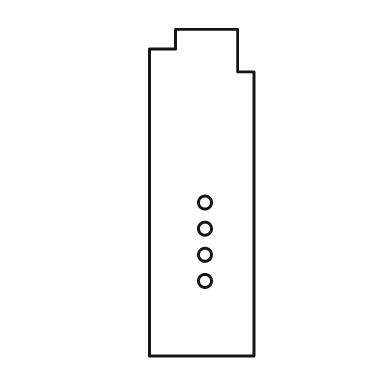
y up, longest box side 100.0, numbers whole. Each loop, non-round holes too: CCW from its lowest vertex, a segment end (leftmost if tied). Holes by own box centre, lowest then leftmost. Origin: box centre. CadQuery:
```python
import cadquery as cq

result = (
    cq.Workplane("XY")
    .moveTo(-16.0, -50.0)
    .lineTo(16.0, -50.0)
    .lineTo(16.0, 37.0)
    .lineTo(11.0, 37.0)
    .lineTo(11.0, 50.0)
    .lineTo(-8.0, 50.0)
    .lineTo(-8.0, 44.0)
    .lineTo(-16.0, 44.0)
    .close()
    .moveTo(1.0, -27.0)
    .circle(2.0)
    .moveTo(1.0, -19.0)
    .circle(2.0)
    .moveTo(1.0, -11.0)
    .circle(2.0)
    .moveTo(1.0, -3.0)
    .circle(2.0)
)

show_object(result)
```